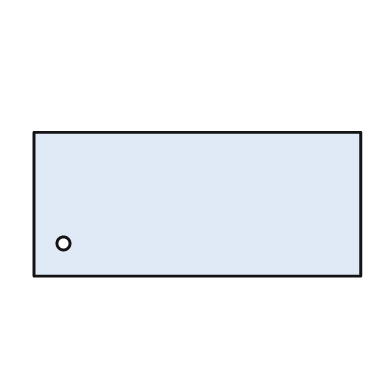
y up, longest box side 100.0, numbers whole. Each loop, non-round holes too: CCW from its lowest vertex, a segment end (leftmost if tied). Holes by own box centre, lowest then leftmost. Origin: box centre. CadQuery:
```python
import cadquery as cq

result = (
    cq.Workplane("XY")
    .moveTo(-50.0, -22.0)
    .lineTo(50.0, -22.0)
    .lineTo(50.0, 22.0)
    .lineTo(-50.0, 22.0)
    .close()
    .moveTo(-41.0, -12.0)
    .circle(2.0)
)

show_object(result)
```